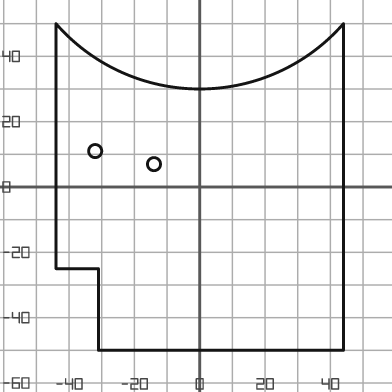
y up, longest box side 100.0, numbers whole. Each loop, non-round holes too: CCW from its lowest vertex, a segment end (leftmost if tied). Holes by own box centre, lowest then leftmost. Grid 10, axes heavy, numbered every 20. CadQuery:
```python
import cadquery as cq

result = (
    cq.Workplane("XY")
    .moveTo(-31.0, -50.0)
    .lineTo(44.0, -50.0)
    .lineTo(44.0, 50.0)
    .threePointArc((0.0, 30.0), (-44.0, 50.0))
    .lineTo(-44.0, -25.0)
    .lineTo(-31.0, -25.0)
    .close()
    .moveTo(-14.0, 7.0)
    .circle(2.0)
    .moveTo(-32.0, 11.0)
    .circle(2.0)
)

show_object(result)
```